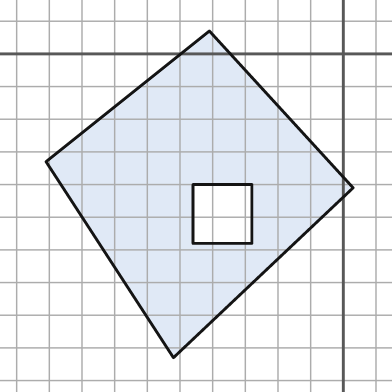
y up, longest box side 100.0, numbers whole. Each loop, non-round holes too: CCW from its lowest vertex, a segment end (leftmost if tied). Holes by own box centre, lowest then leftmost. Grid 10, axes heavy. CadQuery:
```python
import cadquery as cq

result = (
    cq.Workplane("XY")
    .moveTo(-52.0, -93.0)
    .lineTo(3.0, -41.0)
    .lineTo(-41.0, 7.0)
    .lineTo(-91.0, -33.0)
    .close()
    .moveTo(-46.0, -58.0)
    .lineTo(-28.0, -58.0)
    .lineTo(-28.0, -40.0)
    .lineTo(-46.0, -40.0)
    .close()
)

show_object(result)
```